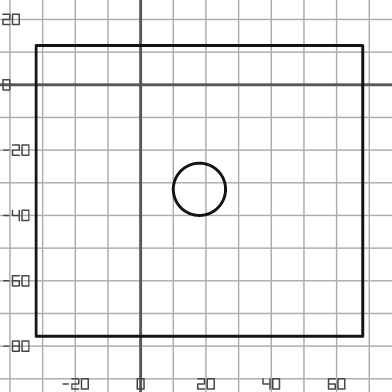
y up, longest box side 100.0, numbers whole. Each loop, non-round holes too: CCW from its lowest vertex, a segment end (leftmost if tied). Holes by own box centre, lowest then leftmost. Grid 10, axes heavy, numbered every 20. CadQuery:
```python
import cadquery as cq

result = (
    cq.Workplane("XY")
    .moveTo(-32.0, -77.0)
    .lineTo(68.0, -77.0)
    .lineTo(68.0, 12.0)
    .lineTo(-32.0, 12.0)
    .close()
    .moveTo(18.0, -32.0)
    .circle(8.0)
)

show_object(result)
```